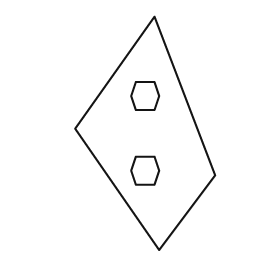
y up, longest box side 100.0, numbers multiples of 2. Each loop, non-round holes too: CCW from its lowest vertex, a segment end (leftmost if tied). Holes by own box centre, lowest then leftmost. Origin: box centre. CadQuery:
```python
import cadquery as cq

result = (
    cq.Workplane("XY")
    .moveTo(6.0, -50.0)
    .lineTo(30.0, -18.0)
    .lineTo(4.0, 50.0)
    .lineTo(-30.0, 2.0)
    .close()
    .moveTo(-4.0, -22.0)
    .lineTo(4.0, -22.0)
    .lineTo(6.0, -16.0)
    .lineTo(4.0, -10.0)
    .lineTo(-4.0, -10.0)
    .lineTo(-6.0, -16.0)
    .close()
    .moveTo(-4.0, 10.0)
    .lineTo(4.0, 10.0)
    .lineTo(6.0, 16.0)
    .lineTo(4.0, 22.0)
    .lineTo(-4.0, 22.0)
    .lineTo(-6.0, 16.0)
    .close()
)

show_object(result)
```